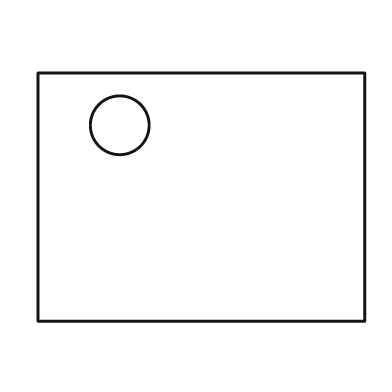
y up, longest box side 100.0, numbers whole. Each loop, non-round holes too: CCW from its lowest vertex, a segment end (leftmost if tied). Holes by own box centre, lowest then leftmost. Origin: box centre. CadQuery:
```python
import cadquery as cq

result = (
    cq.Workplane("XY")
    .moveTo(-50.0, -38.0)
    .lineTo(50.0, -38.0)
    .lineTo(50.0, 38.0)
    .lineTo(-50.0, 38.0)
    .close()
    .moveTo(-25.0, 22.0)
    .circle(9.0)
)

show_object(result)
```